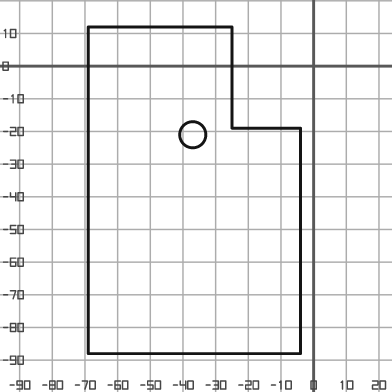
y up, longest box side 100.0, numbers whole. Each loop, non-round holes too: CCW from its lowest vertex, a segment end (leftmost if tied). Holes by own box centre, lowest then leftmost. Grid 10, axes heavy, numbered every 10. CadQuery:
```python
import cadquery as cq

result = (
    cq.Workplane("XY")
    .moveTo(-69.0, -88.0)
    .lineTo(-4.0, -88.0)
    .lineTo(-4.0, -19.0)
    .lineTo(-25.0, -19.0)
    .lineTo(-25.0, 12.0)
    .lineTo(-69.0, 12.0)
    .close()
    .moveTo(-37.0, -21.0)
    .circle(4.0)
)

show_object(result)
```